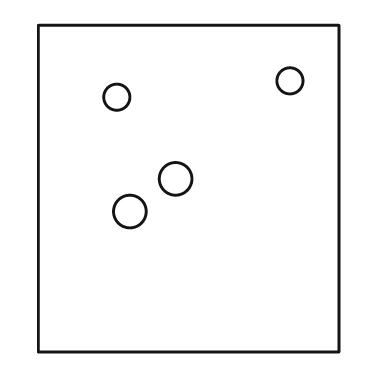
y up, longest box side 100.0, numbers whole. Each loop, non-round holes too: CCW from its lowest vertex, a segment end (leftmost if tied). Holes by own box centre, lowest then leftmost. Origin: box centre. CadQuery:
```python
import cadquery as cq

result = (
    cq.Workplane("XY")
    .moveTo(-46.0, -50.0)
    .lineTo(46.0, -50.0)
    .lineTo(46.0, 50.0)
    .lineTo(-46.0, 50.0)
    .close()
    .moveTo(-18.0, -7.0)
    .circle(5.0)
    .moveTo(-4.0, 3.0)
    .circle(5.0)
    .moveTo(-22.0, 28.0)
    .circle(4.0)
    .moveTo(31.0, 33.0)
    .circle(4.0)
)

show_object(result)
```